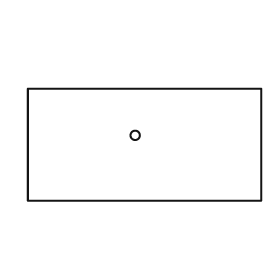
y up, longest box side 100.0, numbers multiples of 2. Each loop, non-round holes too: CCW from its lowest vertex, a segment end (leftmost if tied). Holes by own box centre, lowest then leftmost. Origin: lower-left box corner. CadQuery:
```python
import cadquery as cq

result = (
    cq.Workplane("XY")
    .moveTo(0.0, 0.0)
    .lineTo(100.0, 0.0)
    .lineTo(100.0, 48.0)
    .lineTo(0.0, 48.0)
    .close()
    .moveTo(46.0, 28.0)
    .circle(2.0)
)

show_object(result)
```